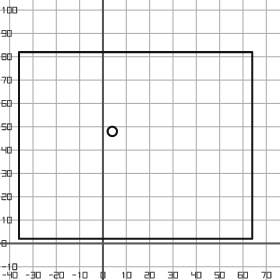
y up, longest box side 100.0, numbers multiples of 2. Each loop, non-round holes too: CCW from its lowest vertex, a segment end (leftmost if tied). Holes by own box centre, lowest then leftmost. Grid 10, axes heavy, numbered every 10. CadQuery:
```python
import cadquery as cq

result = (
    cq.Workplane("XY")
    .moveTo(-36.0, 2.0)
    .lineTo(64.0, 2.0)
    .lineTo(64.0, 82.0)
    .lineTo(-36.0, 82.0)
    .close()
    .moveTo(4.0, 48.0)
    .circle(2.0)
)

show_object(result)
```